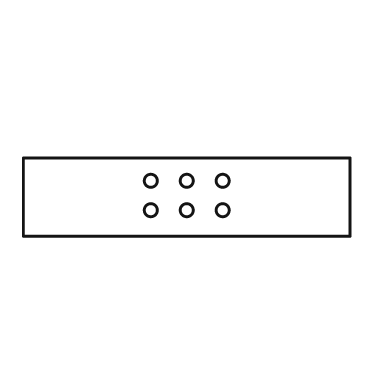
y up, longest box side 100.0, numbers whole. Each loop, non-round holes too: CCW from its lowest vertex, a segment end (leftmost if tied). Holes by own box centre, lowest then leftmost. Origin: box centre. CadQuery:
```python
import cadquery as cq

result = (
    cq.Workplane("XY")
    .moveTo(-50.0, -12.0)
    .lineTo(50.0, -12.0)
    .lineTo(50.0, 12.0)
    .lineTo(-50.0, 12.0)
    .close()
    .moveTo(-11.0, -4.0)
    .circle(2.0)
    .moveTo(0.0, -4.0)
    .circle(2.0)
    .moveTo(11.0, -4.0)
    .circle(2.0)
    .moveTo(-11.0, 5.0)
    .circle(2.0)
    .moveTo(0.0, 5.0)
    .circle(2.0)
    .moveTo(11.0, 5.0)
    .circle(2.0)
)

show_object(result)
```